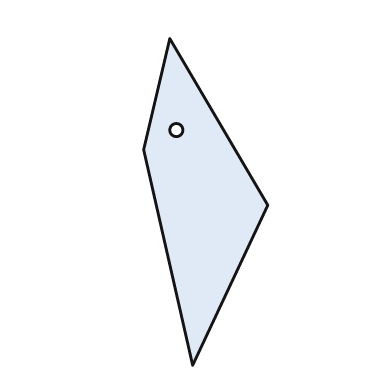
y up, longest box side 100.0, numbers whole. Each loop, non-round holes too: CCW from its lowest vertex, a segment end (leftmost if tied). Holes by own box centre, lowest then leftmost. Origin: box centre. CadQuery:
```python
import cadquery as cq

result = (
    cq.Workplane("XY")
    .moveTo(-4.0, -50.0)
    .lineTo(19.0, -1.0)
    .lineTo(-11.0, 50.0)
    .lineTo(-19.0, 16.0)
    .close()
    .moveTo(-9.0, 22.0)
    .circle(2.0)
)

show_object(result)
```